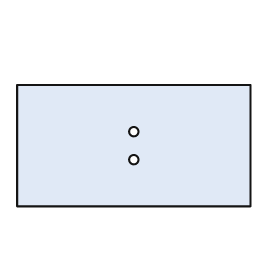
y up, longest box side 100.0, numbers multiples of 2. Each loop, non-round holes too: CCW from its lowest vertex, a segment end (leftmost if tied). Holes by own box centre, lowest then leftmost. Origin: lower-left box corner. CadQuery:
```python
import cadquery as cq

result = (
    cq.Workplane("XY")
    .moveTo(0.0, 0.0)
    .lineTo(100.0, 0.0)
    .lineTo(100.0, 52.0)
    .lineTo(0.0, 52.0)
    .close()
    .moveTo(50.0, 20.0)
    .circle(2.0)
    .moveTo(50.0, 32.0)
    .circle(2.0)
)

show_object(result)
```